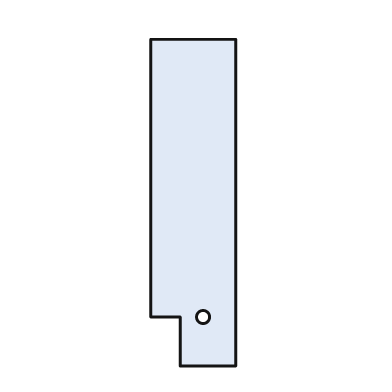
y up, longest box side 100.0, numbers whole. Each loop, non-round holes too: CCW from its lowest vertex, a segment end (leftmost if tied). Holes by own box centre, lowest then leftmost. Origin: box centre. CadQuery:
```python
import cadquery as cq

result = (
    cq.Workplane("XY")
    .moveTo(-4.0, -50.0)
    .lineTo(13.0, -50.0)
    .lineTo(13.0, 50.0)
    .lineTo(-13.0, 50.0)
    .lineTo(-13.0, -35.0)
    .lineTo(-4.0, -35.0)
    .close()
    .moveTo(3.0, -35.0)
    .circle(2.0)
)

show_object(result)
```